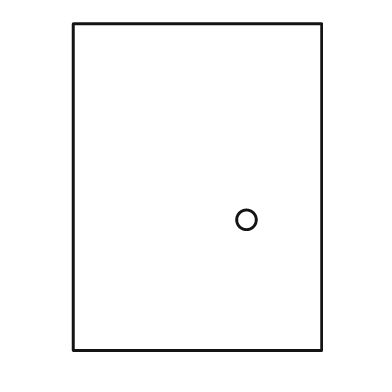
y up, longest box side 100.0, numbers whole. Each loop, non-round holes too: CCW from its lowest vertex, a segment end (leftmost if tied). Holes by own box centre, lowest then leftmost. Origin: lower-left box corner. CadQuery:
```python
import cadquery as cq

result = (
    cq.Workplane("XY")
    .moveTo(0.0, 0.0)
    .lineTo(76.0, 0.0)
    .lineTo(76.0, 100.0)
    .lineTo(0.0, 100.0)
    .close()
    .moveTo(53.0, 40.0)
    .circle(3.0)
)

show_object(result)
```